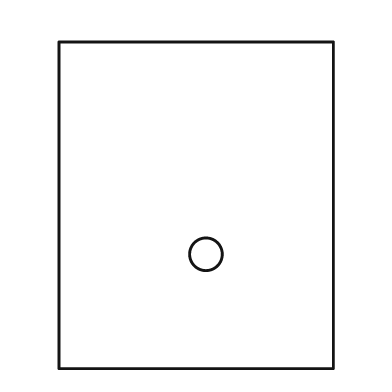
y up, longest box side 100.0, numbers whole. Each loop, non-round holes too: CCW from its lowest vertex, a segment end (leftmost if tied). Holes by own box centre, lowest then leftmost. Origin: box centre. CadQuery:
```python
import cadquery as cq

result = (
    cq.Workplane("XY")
    .moveTo(-42.0, -50.0)
    .lineTo(42.0, -50.0)
    .lineTo(42.0, 50.0)
    .lineTo(-42.0, 50.0)
    .close()
    .moveTo(3.0, -15.0)
    .circle(5.0)
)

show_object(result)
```